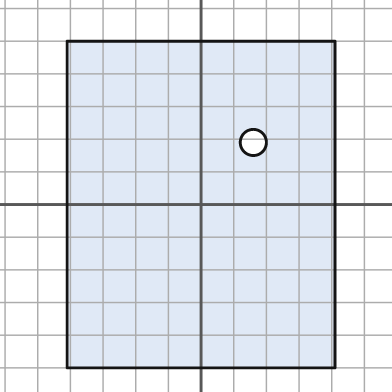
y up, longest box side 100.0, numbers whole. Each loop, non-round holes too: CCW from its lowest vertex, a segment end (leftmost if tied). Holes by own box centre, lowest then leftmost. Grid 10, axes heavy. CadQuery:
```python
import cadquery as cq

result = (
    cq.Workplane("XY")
    .moveTo(-41.0, -50.0)
    .lineTo(41.0, -50.0)
    .lineTo(41.0, 50.0)
    .lineTo(-41.0, 50.0)
    .close()
    .moveTo(16.0, 19.0)
    .circle(4.0)
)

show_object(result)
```